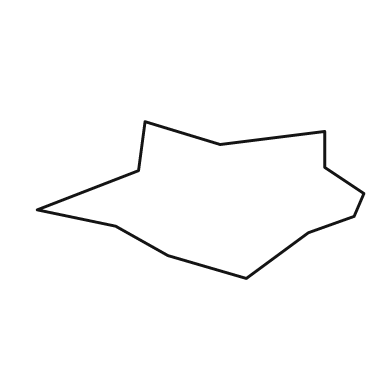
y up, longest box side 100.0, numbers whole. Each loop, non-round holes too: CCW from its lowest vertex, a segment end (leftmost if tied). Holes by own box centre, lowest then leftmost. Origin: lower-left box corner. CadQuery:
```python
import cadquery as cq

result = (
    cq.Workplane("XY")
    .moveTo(64.0, 0.0)
    .lineTo(83.0, 14.0)
    .lineTo(97.0, 19.0)
    .lineTo(100.0, 26.0)
    .lineTo(88.0, 34.0)
    .lineTo(88.0, 45.0)
    .lineTo(56.0, 41.0)
    .lineTo(33.0, 48.0)
    .lineTo(31.0, 33.0)
    .lineTo(0.0, 21.0)
    .lineTo(24.0, 16.0)
    .lineTo(40.0, 7.0)
    .close()
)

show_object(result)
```